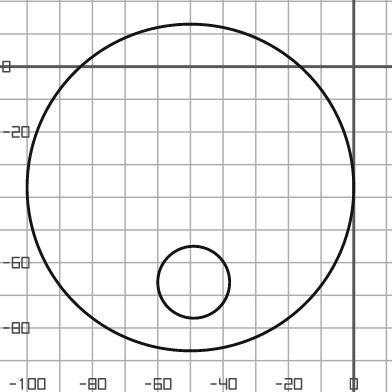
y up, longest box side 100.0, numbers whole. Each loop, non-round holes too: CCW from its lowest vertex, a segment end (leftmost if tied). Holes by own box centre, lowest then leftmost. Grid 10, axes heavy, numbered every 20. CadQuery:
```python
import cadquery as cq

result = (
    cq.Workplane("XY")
    .moveTo(-50.0, -37.0)
    .circle(50.0)
    .moveTo(-49.0, -66.0)
    .circle(11.0)
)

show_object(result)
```